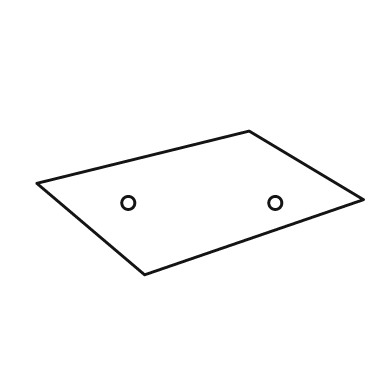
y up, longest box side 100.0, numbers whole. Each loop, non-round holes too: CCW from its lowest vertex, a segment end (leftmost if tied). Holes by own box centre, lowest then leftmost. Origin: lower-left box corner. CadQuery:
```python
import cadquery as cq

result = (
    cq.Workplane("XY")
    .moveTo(33.0, 0.0)
    .lineTo(100.0, 23.0)
    .lineTo(65.0, 44.0)
    .lineTo(0.0, 28.0)
    .close()
    .moveTo(28.0, 22.0)
    .circle(2.0)
    .moveTo(73.0, 22.0)
    .circle(2.0)
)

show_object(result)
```